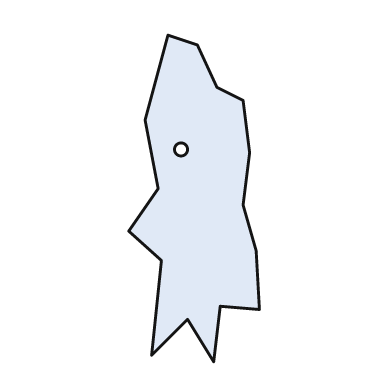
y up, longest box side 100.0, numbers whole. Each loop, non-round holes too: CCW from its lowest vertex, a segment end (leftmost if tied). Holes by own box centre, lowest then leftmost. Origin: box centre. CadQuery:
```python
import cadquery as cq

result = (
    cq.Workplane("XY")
    .moveTo(6.0, -50.0)
    .lineTo(8.0, -33.0)
    .lineTo(20.0, -34.0)
    .lineTo(19.0, -16.0)
    .lineTo(15.0, -2.0)
    .lineTo(17.0, 14.0)
    .lineTo(15.0, 30.0)
    .lineTo(7.0, 34.0)
    .lineTo(1.0, 47.0)
    .lineTo(-8.0, 50.0)
    .lineTo(-15.0, 24.0)
    .lineTo(-11.0, 3.0)
    .lineTo(-20.0, -10.0)
    .lineTo(-10.0, -19.0)
    .lineTo(-13.0, -48.0)
    .lineTo(-2.0, -37.0)
    .close()
    .moveTo(-4.0, 15.0)
    .circle(2.0)
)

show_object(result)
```